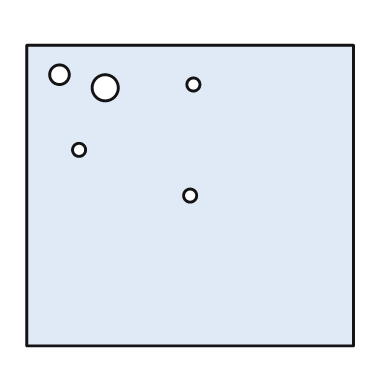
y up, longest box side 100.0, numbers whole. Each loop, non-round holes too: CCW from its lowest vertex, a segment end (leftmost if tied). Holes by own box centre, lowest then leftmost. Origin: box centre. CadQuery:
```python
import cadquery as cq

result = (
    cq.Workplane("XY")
    .moveTo(-50.0, -46.0)
    .lineTo(50.0, -46.0)
    .lineTo(50.0, 46.0)
    .lineTo(-50.0, 46.0)
    .close()
    .moveTo(0.0, 0.0)
    .circle(2.0)
    .moveTo(-34.0, 14.0)
    .circle(2.0)
    .moveTo(-26.0, 33.0)
    .circle(4.0)
    .moveTo(1.0, 34.0)
    .circle(2.0)
    .moveTo(-40.0, 37.0)
    .circle(3.0)
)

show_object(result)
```